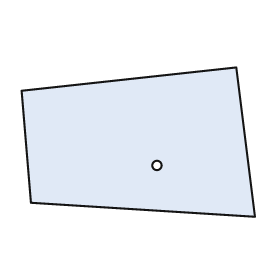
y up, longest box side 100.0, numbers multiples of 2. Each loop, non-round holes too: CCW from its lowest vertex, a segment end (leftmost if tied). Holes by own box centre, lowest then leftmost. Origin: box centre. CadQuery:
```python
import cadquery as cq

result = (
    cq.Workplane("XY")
    .moveTo(50.0, -32.0)
    .lineTo(42.0, 32.0)
    .lineTo(-50.0, 22.0)
    .lineTo(-46.0, -26.0)
    .close()
    .moveTo(8.0, -10.0)
    .circle(2.0)
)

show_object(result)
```